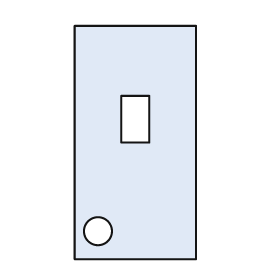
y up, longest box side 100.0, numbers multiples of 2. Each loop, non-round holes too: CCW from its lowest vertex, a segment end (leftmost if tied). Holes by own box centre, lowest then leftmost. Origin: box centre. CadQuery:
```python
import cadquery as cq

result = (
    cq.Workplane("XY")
    .moveTo(-26.0, -50.0)
    .lineTo(26.0, -50.0)
    .lineTo(26.0, 50.0)
    .lineTo(-26.0, 50.0)
    .close()
    .moveTo(-16.0, -38.0)
    .circle(6.0)
    .moveTo(-6.0, 0.0)
    .lineTo(6.0, 0.0)
    .lineTo(6.0, 20.0)
    .lineTo(-6.0, 20.0)
    .close()
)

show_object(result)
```